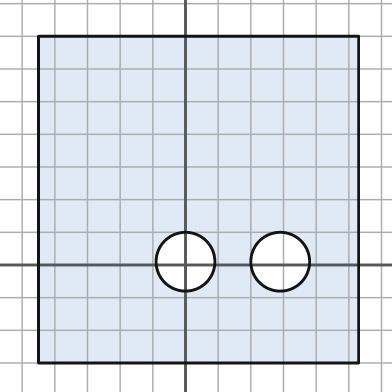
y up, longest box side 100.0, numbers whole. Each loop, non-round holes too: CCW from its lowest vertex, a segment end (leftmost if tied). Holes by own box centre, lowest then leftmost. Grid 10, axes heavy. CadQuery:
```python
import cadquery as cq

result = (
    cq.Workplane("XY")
    .moveTo(-45.0, -30.0)
    .lineTo(53.0, -30.0)
    .lineTo(53.0, 70.0)
    .lineTo(-45.0, 70.0)
    .close()
    .moveTo(0.0, 1.0)
    .circle(9.0)
    .moveTo(29.0, 1.0)
    .circle(9.0)
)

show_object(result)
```